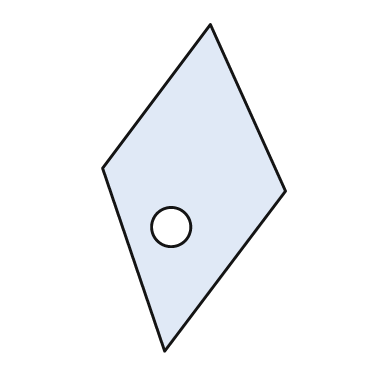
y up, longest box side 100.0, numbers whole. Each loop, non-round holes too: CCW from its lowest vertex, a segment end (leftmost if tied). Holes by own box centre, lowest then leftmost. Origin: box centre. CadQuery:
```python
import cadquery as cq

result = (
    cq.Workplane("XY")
    .moveTo(-9.0, -50.0)
    .lineTo(28.0, -1.0)
    .lineTo(5.0, 50.0)
    .lineTo(-28.0, 6.0)
    .close()
    .moveTo(-7.0, -12.0)
    .circle(6.0)
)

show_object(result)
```